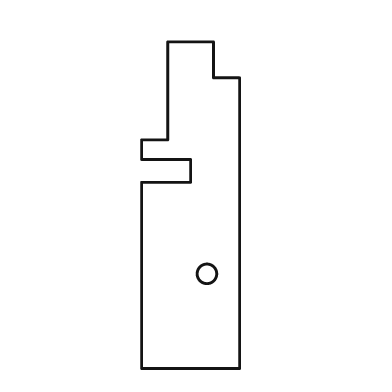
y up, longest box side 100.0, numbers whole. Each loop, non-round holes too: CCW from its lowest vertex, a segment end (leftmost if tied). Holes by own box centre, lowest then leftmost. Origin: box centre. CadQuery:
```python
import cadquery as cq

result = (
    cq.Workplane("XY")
    .moveTo(-15.0, -50.0)
    .lineTo(15.0, -50.0)
    .lineTo(15.0, 39.0)
    .lineTo(7.0, 39.0)
    .lineTo(7.0, 50.0)
    .lineTo(-7.0, 50.0)
    .lineTo(-7.0, 20.0)
    .lineTo(-15.0, 20.0)
    .lineTo(-15.0, 14.0)
    .lineTo(0.0, 14.0)
    .lineTo(0.0, 7.0)
    .lineTo(-15.0, 7.0)
    .close()
    .moveTo(5.0, -21.0)
    .circle(3.0)
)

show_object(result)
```